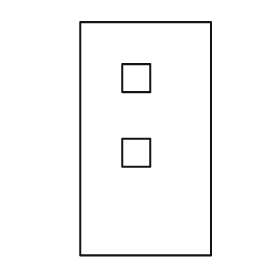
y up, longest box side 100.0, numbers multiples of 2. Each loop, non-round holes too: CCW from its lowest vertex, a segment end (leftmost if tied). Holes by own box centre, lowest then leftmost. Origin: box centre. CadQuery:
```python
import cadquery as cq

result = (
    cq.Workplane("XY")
    .moveTo(-28.0, -50.0)
    .lineTo(28.0, -50.0)
    .lineTo(28.0, 50.0)
    .lineTo(-28.0, 50.0)
    .close()
    .moveTo(-10.0, -12.0)
    .lineTo(2.0, -12.0)
    .lineTo(2.0, 0.0)
    .lineTo(-10.0, 0.0)
    .close()
    .moveTo(-10.0, 20.0)
    .lineTo(2.0, 20.0)
    .lineTo(2.0, 32.0)
    .lineTo(-10.0, 32.0)
    .close()
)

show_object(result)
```